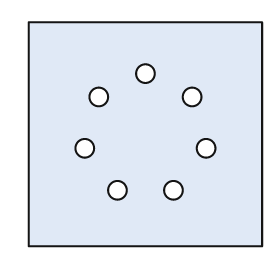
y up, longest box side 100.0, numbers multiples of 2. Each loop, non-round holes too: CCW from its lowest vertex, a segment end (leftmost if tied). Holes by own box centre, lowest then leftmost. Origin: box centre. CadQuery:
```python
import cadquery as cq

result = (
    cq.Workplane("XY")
    .moveTo(-50.0, -48.0)
    .lineTo(50.0, -48.0)
    .lineTo(50.0, 48.0)
    .lineTo(-50.0, 48.0)
    .close()
    .moveTo(-12.0, -24.0)
    .circle(4.0)
    .moveTo(12.0, -24.0)
    .circle(4.0)
    .moveTo(-26.0, -6.0)
    .circle(4.0)
    .moveTo(26.0, -6.0)
    .circle(4.0)
    .moveTo(-20.0, 16.0)
    .circle(4.0)
    .moveTo(20.0, 16.0)
    .circle(4.0)
    .moveTo(0.0, 26.0)
    .circle(4.0)
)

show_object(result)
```